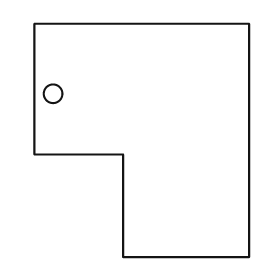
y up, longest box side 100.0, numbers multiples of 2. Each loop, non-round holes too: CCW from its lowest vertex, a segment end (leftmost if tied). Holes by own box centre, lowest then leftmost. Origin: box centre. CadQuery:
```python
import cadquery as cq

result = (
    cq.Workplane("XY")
    .moveTo(-8.0, -50.0)
    .lineTo(46.0, -50.0)
    .lineTo(46.0, 50.0)
    .lineTo(-46.0, 50.0)
    .lineTo(-46.0, -6.0)
    .lineTo(-8.0, -6.0)
    .close()
    .moveTo(-38.0, 20.0)
    .circle(4.0)
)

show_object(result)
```